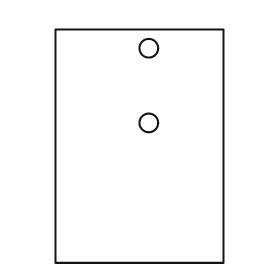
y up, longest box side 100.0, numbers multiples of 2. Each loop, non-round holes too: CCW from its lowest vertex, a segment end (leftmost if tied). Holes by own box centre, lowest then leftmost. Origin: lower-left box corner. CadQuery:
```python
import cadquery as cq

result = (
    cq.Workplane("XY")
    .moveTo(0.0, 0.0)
    .lineTo(72.0, 0.0)
    .lineTo(72.0, 100.0)
    .lineTo(0.0, 100.0)
    .close()
    .moveTo(40.0, 60.0)
    .circle(4.0)
    .moveTo(40.0, 92.0)
    .circle(4.0)
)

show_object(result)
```